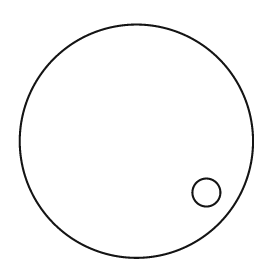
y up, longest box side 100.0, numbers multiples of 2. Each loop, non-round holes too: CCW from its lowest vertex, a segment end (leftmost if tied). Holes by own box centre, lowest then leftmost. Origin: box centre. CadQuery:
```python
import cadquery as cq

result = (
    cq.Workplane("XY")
    .moveTo(0.0, 0.0)
    .circle(50.0)
    .moveTo(30.0, -22.0)
    .circle(6.0)
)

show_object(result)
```